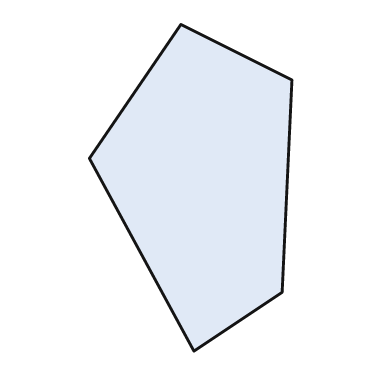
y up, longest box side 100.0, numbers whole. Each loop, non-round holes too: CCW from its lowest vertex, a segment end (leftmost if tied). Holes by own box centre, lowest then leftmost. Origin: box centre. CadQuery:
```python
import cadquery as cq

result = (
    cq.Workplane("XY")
    .moveTo(1.0, -50.0)
    .lineTo(28.0, -32.0)
    .lineTo(31.0, 33.0)
    .lineTo(-3.0, 50.0)
    .lineTo(-31.0, 9.0)
    .close()
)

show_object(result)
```